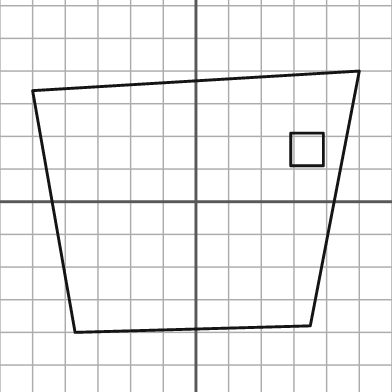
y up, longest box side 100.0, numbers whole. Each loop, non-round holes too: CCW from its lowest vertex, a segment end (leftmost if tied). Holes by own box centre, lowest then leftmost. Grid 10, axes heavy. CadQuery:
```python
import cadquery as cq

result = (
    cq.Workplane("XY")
    .moveTo(-37.0, -40.0)
    .lineTo(35.0, -38.0)
    .lineTo(50.0, 40.0)
    .lineTo(-50.0, 34.0)
    .close()
    .moveTo(29.0, 11.0)
    .lineTo(39.0, 11.0)
    .lineTo(39.0, 21.0)
    .lineTo(29.0, 21.0)
    .close()
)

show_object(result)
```